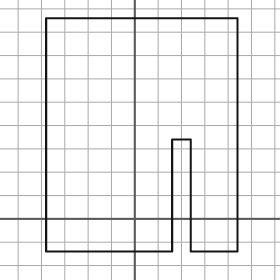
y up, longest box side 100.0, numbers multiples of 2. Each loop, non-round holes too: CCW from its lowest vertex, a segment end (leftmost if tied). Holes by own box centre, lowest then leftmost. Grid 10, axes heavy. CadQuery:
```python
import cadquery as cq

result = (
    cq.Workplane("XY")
    .moveTo(-38.0, -14.0)
    .lineTo(16.0, -14.0)
    .lineTo(16.0, 34.0)
    .lineTo(24.0, 34.0)
    .lineTo(24.0, -14.0)
    .lineTo(44.0, -14.0)
    .lineTo(44.0, 86.0)
    .lineTo(-38.0, 86.0)
    .close()
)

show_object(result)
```